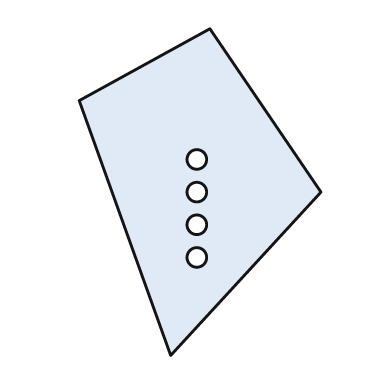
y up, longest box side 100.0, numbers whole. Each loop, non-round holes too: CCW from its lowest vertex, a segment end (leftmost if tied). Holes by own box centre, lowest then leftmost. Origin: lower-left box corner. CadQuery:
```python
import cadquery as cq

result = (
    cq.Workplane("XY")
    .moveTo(28.0, 0.0)
    .lineTo(74.0, 50.0)
    .lineTo(40.0, 100.0)
    .lineTo(0.0, 78.0)
    .close()
    .moveTo(36.0, 30.0)
    .circle(3.0)
    .moveTo(36.0, 40.0)
    .circle(3.0)
    .moveTo(36.0, 50.0)
    .circle(3.0)
    .moveTo(36.0, 60.0)
    .circle(3.0)
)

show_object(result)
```